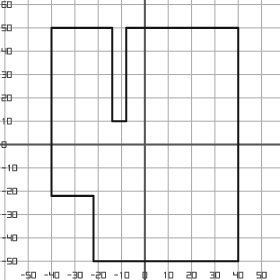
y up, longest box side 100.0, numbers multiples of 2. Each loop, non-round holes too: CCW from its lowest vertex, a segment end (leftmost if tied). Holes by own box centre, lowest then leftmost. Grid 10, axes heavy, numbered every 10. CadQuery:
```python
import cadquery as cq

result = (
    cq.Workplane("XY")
    .moveTo(-22.0, -50.0)
    .lineTo(40.0, -50.0)
    .lineTo(40.0, 50.0)
    .lineTo(-8.0, 50.0)
    .lineTo(-8.0, 10.0)
    .lineTo(-14.0, 10.0)
    .lineTo(-14.0, 50.0)
    .lineTo(-40.0, 50.0)
    .lineTo(-40.0, -22.0)
    .lineTo(-22.0, -22.0)
    .close()
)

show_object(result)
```